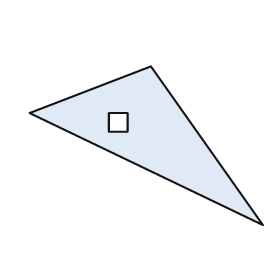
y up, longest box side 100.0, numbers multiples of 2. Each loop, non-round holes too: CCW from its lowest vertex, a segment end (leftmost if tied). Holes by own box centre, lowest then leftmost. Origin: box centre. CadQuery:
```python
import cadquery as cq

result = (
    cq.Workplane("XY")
    .moveTo(50.0, -34.0)
    .lineTo(2.0, 34.0)
    .lineTo(-50.0, 14.0)
    .close()
    .moveTo(-16.0, 6.0)
    .lineTo(-8.0, 6.0)
    .lineTo(-8.0, 14.0)
    .lineTo(-16.0, 14.0)
    .close()
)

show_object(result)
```